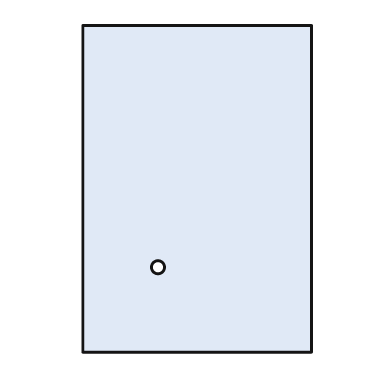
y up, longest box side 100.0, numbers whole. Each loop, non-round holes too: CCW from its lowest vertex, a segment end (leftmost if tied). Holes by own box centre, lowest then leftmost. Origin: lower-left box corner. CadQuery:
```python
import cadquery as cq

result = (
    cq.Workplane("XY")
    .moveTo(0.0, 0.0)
    .lineTo(70.0, 0.0)
    .lineTo(70.0, 100.0)
    .lineTo(0.0, 100.0)
    .close()
    .moveTo(23.0, 26.0)
    .circle(2.0)
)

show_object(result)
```